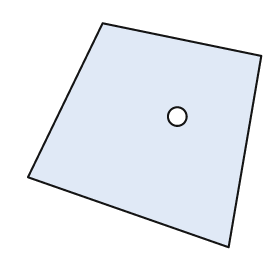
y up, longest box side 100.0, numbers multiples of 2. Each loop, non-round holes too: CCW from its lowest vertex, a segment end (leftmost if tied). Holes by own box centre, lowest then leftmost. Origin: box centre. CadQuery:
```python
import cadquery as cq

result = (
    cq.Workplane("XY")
    .moveTo(36.0, -48.0)
    .lineTo(50.0, 34.0)
    .lineTo(-18.0, 48.0)
    .lineTo(-50.0, -18.0)
    .close()
    .moveTo(14.0, 8.0)
    .circle(4.0)
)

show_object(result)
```